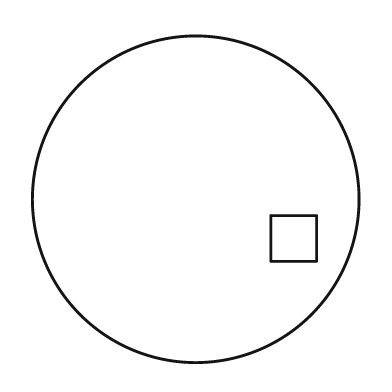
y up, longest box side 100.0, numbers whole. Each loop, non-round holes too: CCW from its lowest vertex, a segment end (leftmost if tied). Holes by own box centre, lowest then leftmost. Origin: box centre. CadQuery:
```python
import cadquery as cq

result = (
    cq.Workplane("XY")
    .moveTo(0.0, 0.0)
    .circle(50.0)
    .moveTo(23.0, -19.0)
    .lineTo(37.0, -19.0)
    .lineTo(37.0, -5.0)
    .lineTo(23.0, -5.0)
    .close()
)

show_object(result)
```